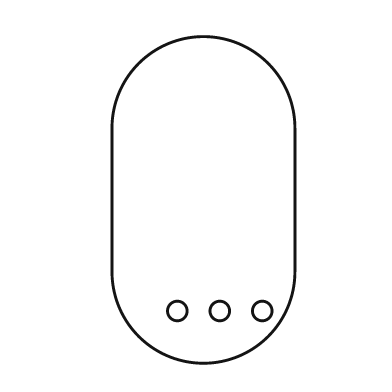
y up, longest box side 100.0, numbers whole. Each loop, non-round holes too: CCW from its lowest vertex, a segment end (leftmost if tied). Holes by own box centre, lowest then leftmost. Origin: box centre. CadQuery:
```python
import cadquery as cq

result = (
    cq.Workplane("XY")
    .moveTo(-28.0, -22.0)
    .threePointArc((0.0, -50.0), (28.0, -22.0))
    .lineTo(28.0, 22.0)
    .threePointArc((0.0, 50.0), (-28.0, 22.0))
    .close()
    .moveTo(-8.0, -34.0)
    .circle(3.0)
    .moveTo(5.0, -34.0)
    .circle(3.0)
    .moveTo(18.0, -34.0)
    .circle(3.0)
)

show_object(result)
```